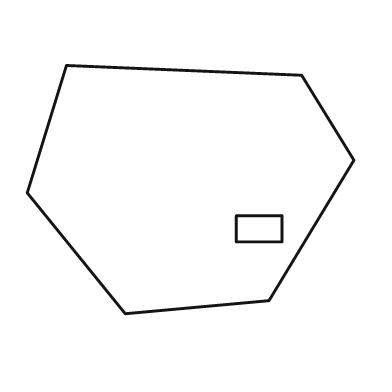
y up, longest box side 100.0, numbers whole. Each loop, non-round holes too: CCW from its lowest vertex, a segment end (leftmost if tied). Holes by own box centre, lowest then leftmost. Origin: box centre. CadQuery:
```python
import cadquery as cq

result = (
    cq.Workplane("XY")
    .moveTo(-20.0, -38.0)
    .lineTo(24.0, -34.0)
    .lineTo(50.0, 9.0)
    .lineTo(34.0, 35.0)
    .lineTo(-38.0, 38.0)
    .lineTo(-50.0, -1.0)
    .close()
    .moveTo(14.0, -16.0)
    .lineTo(28.0, -16.0)
    .lineTo(28.0, -8.0)
    .lineTo(14.0, -8.0)
    .close()
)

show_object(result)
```